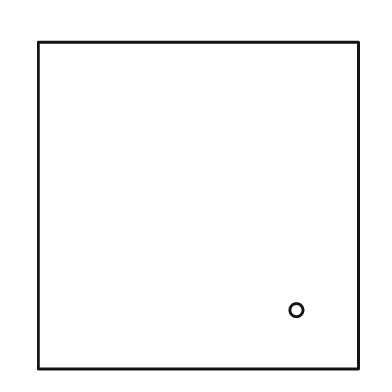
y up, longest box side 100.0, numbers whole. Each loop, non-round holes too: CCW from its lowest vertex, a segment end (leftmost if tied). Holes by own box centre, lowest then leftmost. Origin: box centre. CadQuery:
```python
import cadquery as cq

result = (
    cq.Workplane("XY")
    .moveTo(-49.0, -50.0)
    .lineTo(49.0, -50.0)
    .lineTo(49.0, 50.0)
    .lineTo(-49.0, 50.0)
    .close()
    .moveTo(30.0, -32.0)
    .circle(2.0)
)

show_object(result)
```